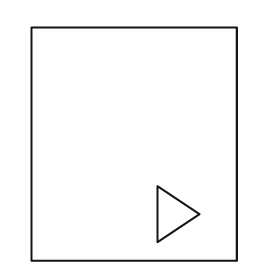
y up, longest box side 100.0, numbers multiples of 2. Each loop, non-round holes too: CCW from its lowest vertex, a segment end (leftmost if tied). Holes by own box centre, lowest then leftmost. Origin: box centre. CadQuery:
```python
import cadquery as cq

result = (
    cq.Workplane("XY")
    .moveTo(-44.0, -50.0)
    .lineTo(44.0, -50.0)
    .lineTo(44.0, 50.0)
    .lineTo(-44.0, 50.0)
    .close()
    .moveTo(10.0, -42.0)
    .lineTo(28.0, -30.0)
    .lineTo(10.0, -18.0)
    .close()
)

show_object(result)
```